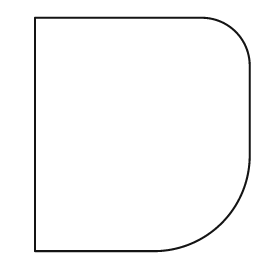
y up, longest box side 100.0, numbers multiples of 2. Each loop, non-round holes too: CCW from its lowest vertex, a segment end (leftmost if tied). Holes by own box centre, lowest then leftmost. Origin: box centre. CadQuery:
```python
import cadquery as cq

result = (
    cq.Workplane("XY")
    .moveTo(-46.0, -50.0)
    .lineTo(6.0, -50.0)
    .threePointArc((34.0, -38.0), (46.0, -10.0))
    .lineTo(46.0, 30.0)
    .threePointArc((40.0, 44.0), (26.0, 50.0))
    .lineTo(-46.0, 50.0)
    .close()
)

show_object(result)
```